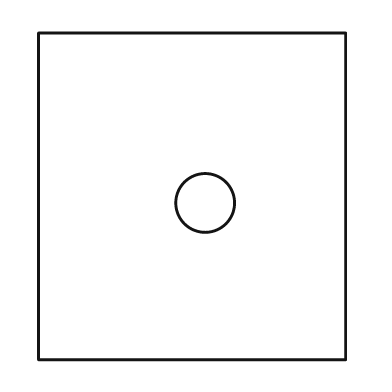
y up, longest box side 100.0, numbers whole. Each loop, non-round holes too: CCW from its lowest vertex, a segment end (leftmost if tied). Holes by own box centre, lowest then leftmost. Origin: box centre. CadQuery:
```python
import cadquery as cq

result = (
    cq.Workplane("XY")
    .moveTo(-47.0, -50.0)
    .lineTo(47.0, -50.0)
    .lineTo(47.0, 50.0)
    .lineTo(-47.0, 50.0)
    .close()
    .moveTo(4.0, -2.0)
    .circle(9.0)
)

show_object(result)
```